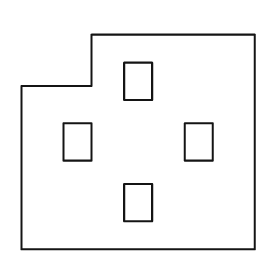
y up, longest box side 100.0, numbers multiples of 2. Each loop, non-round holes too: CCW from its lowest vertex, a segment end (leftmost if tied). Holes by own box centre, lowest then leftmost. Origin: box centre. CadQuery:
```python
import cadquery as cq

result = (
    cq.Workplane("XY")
    .moveTo(-50.0, -46.0)
    .lineTo(50.0, -46.0)
    .lineTo(50.0, 46.0)
    .lineTo(-20.0, 46.0)
    .lineTo(-20.0, 24.0)
    .lineTo(-50.0, 24.0)
    .close()
    .moveTo(-6.0, -34.0)
    .lineTo(6.0, -34.0)
    .lineTo(6.0, -18.0)
    .lineTo(-6.0, -18.0)
    .close()
    .moveTo(-32.0, -8.0)
    .lineTo(-20.0, -8.0)
    .lineTo(-20.0, 8.0)
    .lineTo(-32.0, 8.0)
    .close()
    .moveTo(20.0, -8.0)
    .lineTo(32.0, -8.0)
    .lineTo(32.0, 8.0)
    .lineTo(20.0, 8.0)
    .close()
    .moveTo(-6.0, 18.0)
    .lineTo(6.0, 18.0)
    .lineTo(6.0, 34.0)
    .lineTo(-6.0, 34.0)
    .close()
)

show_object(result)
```